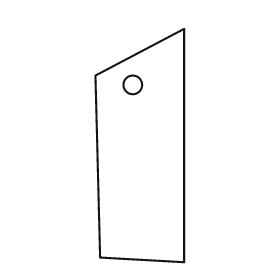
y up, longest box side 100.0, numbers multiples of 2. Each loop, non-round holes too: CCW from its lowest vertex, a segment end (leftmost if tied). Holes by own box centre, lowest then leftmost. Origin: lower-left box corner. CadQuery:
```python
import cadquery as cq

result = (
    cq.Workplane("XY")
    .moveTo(38.0, 0.0)
    .lineTo(38.0, 100.0)
    .lineTo(0.0, 80.0)
    .lineTo(2.0, 2.0)
    .close()
    .moveTo(16.0, 76.0)
    .circle(4.0)
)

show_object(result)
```